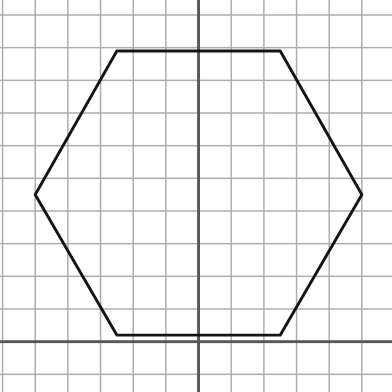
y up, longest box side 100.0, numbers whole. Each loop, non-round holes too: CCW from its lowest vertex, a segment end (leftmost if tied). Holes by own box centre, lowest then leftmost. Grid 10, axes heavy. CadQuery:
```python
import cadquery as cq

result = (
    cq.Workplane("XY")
    .moveTo(-25.0, 2.0)
    .lineTo(25.0, 2.0)
    .lineTo(50.0, 45.0)
    .lineTo(25.0, 89.0)
    .lineTo(-25.0, 89.0)
    .lineTo(-50.0, 45.0)
    .close()
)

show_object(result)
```